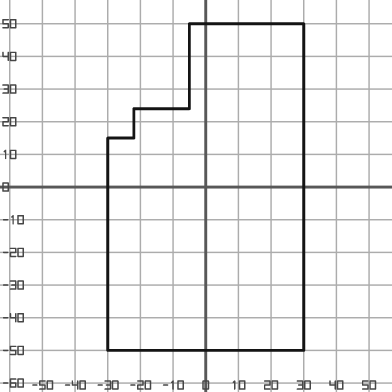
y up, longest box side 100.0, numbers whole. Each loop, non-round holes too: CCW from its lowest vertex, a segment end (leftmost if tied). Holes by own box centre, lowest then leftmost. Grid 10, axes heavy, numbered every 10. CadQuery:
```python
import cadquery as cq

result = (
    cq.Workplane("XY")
    .moveTo(-30.0, -50.0)
    .lineTo(30.0, -50.0)
    .lineTo(30.0, 50.0)
    .lineTo(-5.0, 50.0)
    .lineTo(-5.0, 24.0)
    .lineTo(-22.0, 24.0)
    .lineTo(-22.0, 15.0)
    .lineTo(-30.0, 15.0)
    .close()
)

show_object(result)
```